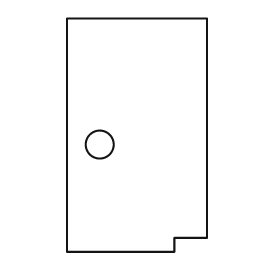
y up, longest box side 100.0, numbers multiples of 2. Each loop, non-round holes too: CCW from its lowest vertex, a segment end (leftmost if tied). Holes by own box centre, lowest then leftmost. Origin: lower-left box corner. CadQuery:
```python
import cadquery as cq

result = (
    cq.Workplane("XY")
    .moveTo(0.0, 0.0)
    .lineTo(46.0, 0.0)
    .lineTo(46.0, 6.0)
    .lineTo(60.0, 6.0)
    .lineTo(60.0, 100.0)
    .lineTo(0.0, 100.0)
    .close()
    .moveTo(14.0, 46.0)
    .circle(6.0)
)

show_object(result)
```